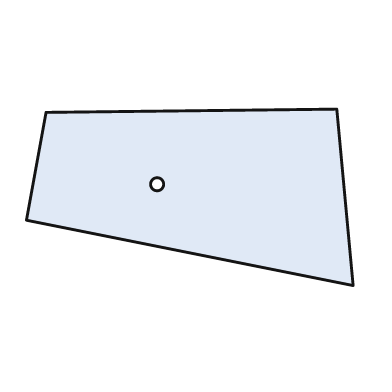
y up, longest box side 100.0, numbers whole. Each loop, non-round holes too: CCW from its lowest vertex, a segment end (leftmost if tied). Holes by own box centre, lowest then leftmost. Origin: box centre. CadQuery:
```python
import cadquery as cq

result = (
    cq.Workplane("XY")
    .moveTo(50.0, -27.0)
    .lineTo(45.0, 27.0)
    .lineTo(-44.0, 26.0)
    .lineTo(-50.0, -7.0)
    .close()
    .moveTo(-10.0, 4.0)
    .circle(2.0)
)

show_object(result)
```